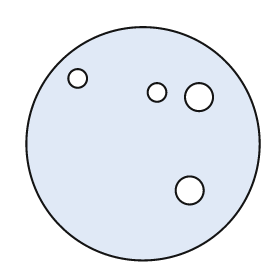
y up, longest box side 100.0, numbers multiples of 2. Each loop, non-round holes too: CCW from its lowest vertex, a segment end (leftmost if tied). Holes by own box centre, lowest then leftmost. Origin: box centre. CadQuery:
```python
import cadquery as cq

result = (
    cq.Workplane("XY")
    .moveTo(0.0, 0.0)
    .circle(50.0)
    .moveTo(20.0, -20.0)
    .circle(6.0)
    .moveTo(24.0, 20.0)
    .circle(6.0)
    .moveTo(6.0, 22.0)
    .circle(4.0)
    .moveTo(-28.0, 28.0)
    .circle(4.0)
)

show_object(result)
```